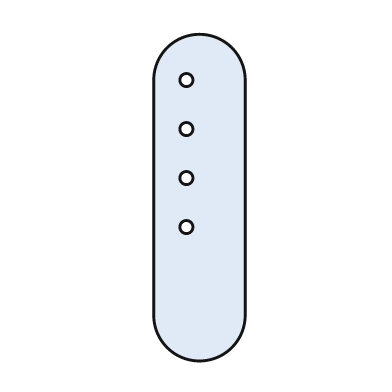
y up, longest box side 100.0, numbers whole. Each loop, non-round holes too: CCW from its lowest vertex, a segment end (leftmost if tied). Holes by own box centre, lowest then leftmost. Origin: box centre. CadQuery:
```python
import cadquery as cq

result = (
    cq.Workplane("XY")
    .moveTo(-14.0, -36.0)
    .threePointArc((0.0, -50.0), (14.0, -36.0))
    .lineTo(14.0, 36.0)
    .threePointArc((0.0, 50.0), (-14.0, 36.0))
    .close()
    .moveTo(-4.0, -9.0)
    .circle(2.0)
    .moveTo(-4.0, 6.0)
    .circle(2.0)
    .moveTo(-4.0, 21.0)
    .circle(2.0)
    .moveTo(-4.0, 36.0)
    .circle(2.0)
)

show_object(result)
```